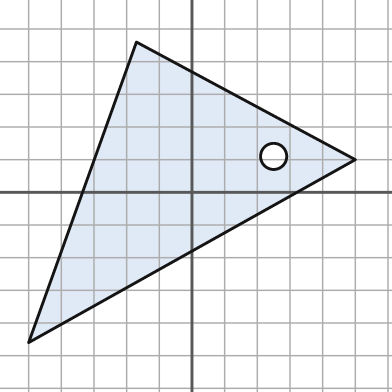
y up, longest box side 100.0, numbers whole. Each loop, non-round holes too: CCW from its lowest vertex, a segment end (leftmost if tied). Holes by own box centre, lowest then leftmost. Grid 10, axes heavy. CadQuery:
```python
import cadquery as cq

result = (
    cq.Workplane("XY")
    .moveTo(-50.0, -46.0)
    .lineTo(50.0, 10.0)
    .lineTo(-17.0, 46.0)
    .close()
    .moveTo(25.0, 11.0)
    .circle(4.0)
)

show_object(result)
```